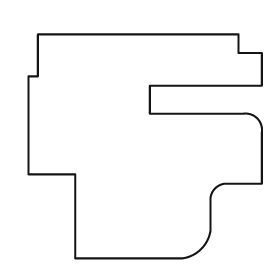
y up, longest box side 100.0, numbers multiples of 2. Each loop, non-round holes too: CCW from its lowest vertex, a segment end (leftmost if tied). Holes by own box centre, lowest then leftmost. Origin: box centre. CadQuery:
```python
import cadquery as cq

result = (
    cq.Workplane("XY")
    .moveTo(-30.0, -48.0)
    .lineTo(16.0, -48.0)
    .threePointArc((24.0, -44.0), (28.0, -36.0))
    .lineTo(28.0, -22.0)
    .threePointArc((30.0, -18.0), (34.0, -16.0))
    .lineTo(50.0, -16.0)
    .lineTo(50.0, 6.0)
    .threePointArc((48.0, 12.0), (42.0, 14.0))
    .lineTo(2.0, 14.0)
    .lineTo(2.0, 26.0)
    .lineTo(50.0, 26.0)
    .lineTo(50.0, 40.0)
    .lineTo(40.0, 40.0)
    .lineTo(40.0, 48.0)
    .lineTo(-46.0, 48.0)
    .lineTo(-46.0, 30.0)
    .lineTo(-50.0, 30.0)
    .lineTo(-50.0, -12.0)
    .lineTo(-30.0, -12.0)
    .close()
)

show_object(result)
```